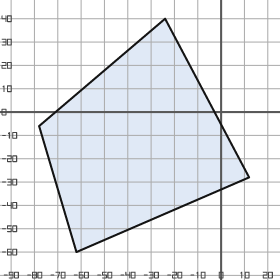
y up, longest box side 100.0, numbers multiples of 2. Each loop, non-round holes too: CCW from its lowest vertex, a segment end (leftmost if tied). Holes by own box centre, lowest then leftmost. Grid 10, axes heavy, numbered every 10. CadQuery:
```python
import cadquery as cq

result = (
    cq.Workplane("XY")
    .moveTo(-62.0, -60.0)
    .lineTo(12.0, -28.0)
    .lineTo(-24.0, 40.0)
    .lineTo(-78.0, -6.0)
    .close()
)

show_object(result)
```